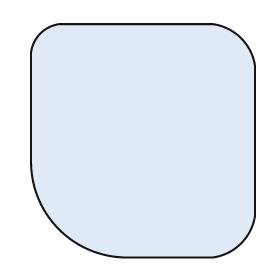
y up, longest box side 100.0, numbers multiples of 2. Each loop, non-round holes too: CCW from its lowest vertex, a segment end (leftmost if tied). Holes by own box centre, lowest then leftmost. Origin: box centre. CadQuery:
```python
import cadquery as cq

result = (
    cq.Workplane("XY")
    .moveTo(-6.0, -50.0)
    .lineTo(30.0, -50.0)
    .threePointArc((42.0, -44.0), (48.0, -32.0))
    .lineTo(48.0, 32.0)
    .threePointArc((42.0, 44.0), (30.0, 50.0))
    .lineTo(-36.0, 50.0)
    .threePointArc((-44.0, 46.0), (-48.0, 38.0))
    .lineTo(-48.0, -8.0)
    .threePointArc((-36.0, -38.0), (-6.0, -50.0))
    .close()
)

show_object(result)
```